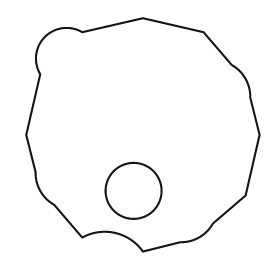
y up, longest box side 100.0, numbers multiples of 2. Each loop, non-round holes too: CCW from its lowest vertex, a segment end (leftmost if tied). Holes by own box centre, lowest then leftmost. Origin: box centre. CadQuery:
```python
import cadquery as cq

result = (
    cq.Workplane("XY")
    .moveTo(0.0, -50.0)
    .lineTo(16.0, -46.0)
    .threePointArc((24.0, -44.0), (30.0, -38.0))
    .lineTo(44.0, -26.0)
    .lineTo(50.0, 0.0)
    .lineTo(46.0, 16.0)
    .threePointArc((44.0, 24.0), (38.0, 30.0))
    .lineTo(26.0, 44.0)
    .lineTo(0.0, 50.0)
    .lineTo(-26.0, 44.0)
    .threePointArc((-42.0, 42.0), (-44.0, 26.0))
    .lineTo(-50.0, 0.0)
    .lineTo(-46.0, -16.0)
    .threePointArc((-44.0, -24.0), (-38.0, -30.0))
    .lineTo(-26.0, -44.0)
    .threePointArc((-12.0, -42.0), (0.0, -50.0))
    .close()
    .moveTo(-4.0, -24.0)
    .circle(12.0)
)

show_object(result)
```